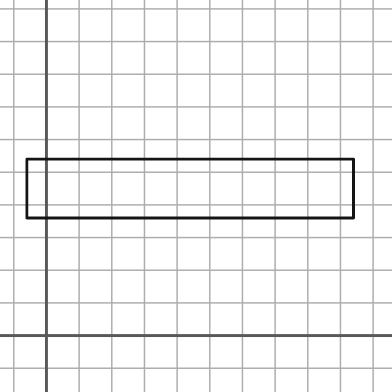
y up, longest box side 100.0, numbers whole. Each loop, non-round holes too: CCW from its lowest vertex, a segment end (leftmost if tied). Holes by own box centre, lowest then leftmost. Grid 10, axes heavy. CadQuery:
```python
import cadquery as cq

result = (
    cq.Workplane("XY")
    .moveTo(-6.0, 36.0)
    .lineTo(94.0, 36.0)
    .lineTo(94.0, 54.0)
    .lineTo(-6.0, 54.0)
    .close()
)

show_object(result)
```